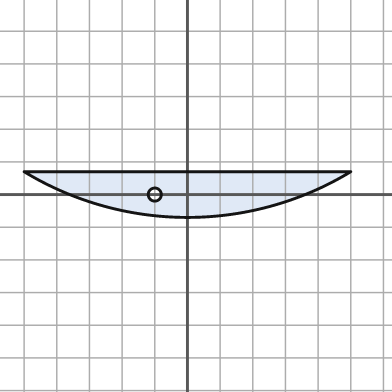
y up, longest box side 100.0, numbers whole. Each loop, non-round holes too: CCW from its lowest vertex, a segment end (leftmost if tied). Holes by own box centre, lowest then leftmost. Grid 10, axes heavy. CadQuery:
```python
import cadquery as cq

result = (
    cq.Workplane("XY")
    .moveTo(-50.0, 7.0)
    .threePointArc((0.0, -7.0), (50.0, 7.0))
    .close()
    .moveTo(-10.0, 0.0)
    .circle(2.0)
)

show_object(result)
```